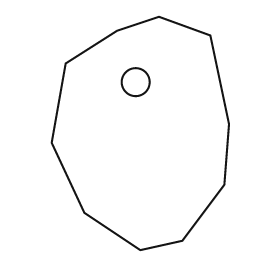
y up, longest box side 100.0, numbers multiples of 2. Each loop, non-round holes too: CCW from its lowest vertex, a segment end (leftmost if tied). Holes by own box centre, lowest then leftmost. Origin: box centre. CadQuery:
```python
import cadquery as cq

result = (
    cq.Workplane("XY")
    .moveTo(0.0, -50.0)
    .lineTo(18.0, -46.0)
    .lineTo(36.0, -22.0)
    .lineTo(38.0, 4.0)
    .lineTo(30.0, 42.0)
    .lineTo(8.0, 50.0)
    .lineTo(-10.0, 44.0)
    .lineTo(-32.0, 30.0)
    .lineTo(-38.0, -4.0)
    .lineTo(-24.0, -34.0)
    .close()
    .moveTo(-2.0, 22.0)
    .circle(6.0)
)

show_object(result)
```